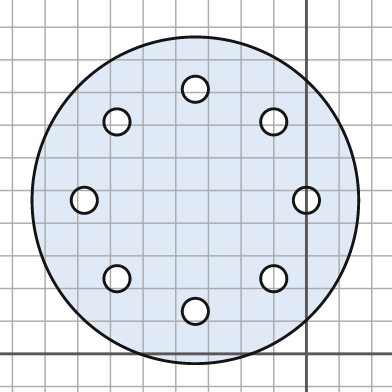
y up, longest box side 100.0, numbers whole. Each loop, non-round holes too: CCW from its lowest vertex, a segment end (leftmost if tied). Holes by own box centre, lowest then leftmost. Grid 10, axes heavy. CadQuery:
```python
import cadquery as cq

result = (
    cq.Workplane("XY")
    .moveTo(-34.0, 47.0)
    .circle(50.0)
    .moveTo(-34.0, 13.0)
    .circle(4.0)
    .moveTo(-58.0, 23.0)
    .circle(4.0)
    .moveTo(-10.0, 23.0)
    .circle(4.0)
    .moveTo(-68.0, 47.0)
    .circle(4.0)
    .moveTo(0.0, 47.0)
    .circle(4.0)
    .moveTo(-58.0, 71.0)
    .circle(4.0)
    .moveTo(-10.0, 71.0)
    .circle(4.0)
    .moveTo(-34.0, 81.0)
    .circle(4.0)
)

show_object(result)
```